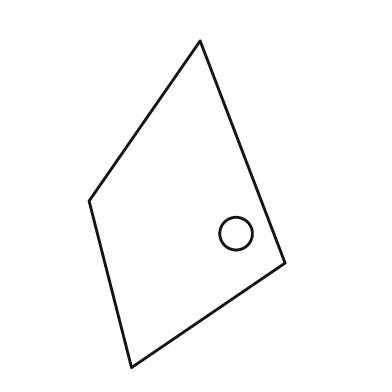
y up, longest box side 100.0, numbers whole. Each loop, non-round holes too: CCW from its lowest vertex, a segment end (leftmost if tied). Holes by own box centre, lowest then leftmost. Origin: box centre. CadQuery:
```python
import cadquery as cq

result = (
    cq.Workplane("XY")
    .moveTo(-17.0, -50.0)
    .lineTo(30.0, -18.0)
    .lineTo(4.0, 50.0)
    .lineTo(-30.0, 1.0)
    .close()
    .moveTo(15.0, -9.0)
    .circle(5.0)
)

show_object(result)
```